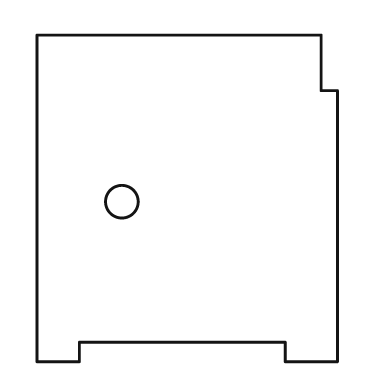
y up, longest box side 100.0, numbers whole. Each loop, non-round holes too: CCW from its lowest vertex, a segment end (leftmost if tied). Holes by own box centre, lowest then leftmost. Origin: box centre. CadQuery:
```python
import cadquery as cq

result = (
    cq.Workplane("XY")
    .moveTo(-46.0, -50.0)
    .lineTo(-33.0, -50.0)
    .lineTo(-33.0, -44.0)
    .lineTo(30.0, -44.0)
    .lineTo(30.0, -50.0)
    .lineTo(46.0, -50.0)
    .lineTo(46.0, 33.0)
    .lineTo(41.0, 33.0)
    .lineTo(41.0, 50.0)
    .lineTo(-46.0, 50.0)
    .close()
    .moveTo(-20.0, -1.0)
    .circle(5.0)
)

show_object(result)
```